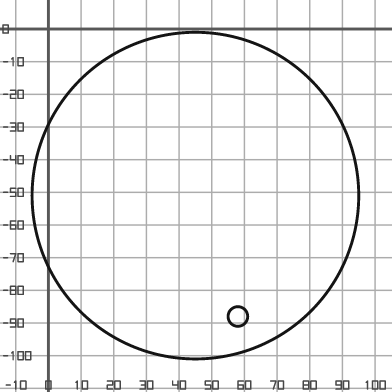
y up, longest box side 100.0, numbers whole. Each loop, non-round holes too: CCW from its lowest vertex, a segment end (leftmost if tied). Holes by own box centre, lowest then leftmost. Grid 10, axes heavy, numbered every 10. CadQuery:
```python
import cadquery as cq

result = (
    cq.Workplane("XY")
    .moveTo(45.0, -51.0)
    .circle(50.0)
    .moveTo(58.0, -88.0)
    .circle(3.0)
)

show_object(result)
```